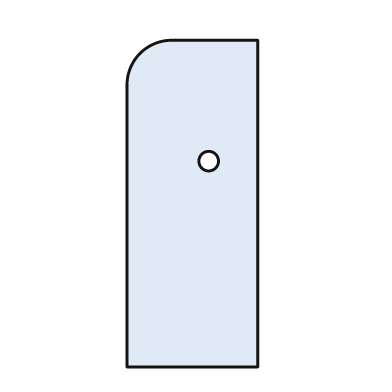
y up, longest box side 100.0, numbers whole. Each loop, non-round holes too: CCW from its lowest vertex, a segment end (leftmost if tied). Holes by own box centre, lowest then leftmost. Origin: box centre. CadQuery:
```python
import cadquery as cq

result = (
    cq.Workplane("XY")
    .moveTo(-20.0, -50.0)
    .lineTo(20.0, -50.0)
    .lineTo(20.0, 50.0)
    .lineTo(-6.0, 50.0)
    .threePointArc((-16.0, 46.0), (-20.0, 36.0))
    .close()
    .moveTo(5.0, 13.0)
    .circle(3.0)
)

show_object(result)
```